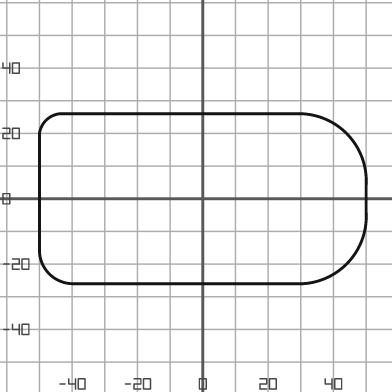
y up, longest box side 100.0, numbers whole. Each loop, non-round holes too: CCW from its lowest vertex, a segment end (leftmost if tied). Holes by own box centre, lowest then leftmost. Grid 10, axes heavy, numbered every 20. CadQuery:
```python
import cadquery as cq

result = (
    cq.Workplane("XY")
    .moveTo(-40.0, -26.0)
    .lineTo(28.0, -26.0)
    .threePointArc((44.0, -20.0), (50.0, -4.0))
    .lineTo(50.0, 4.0)
    .threePointArc((44.0, 20.0), (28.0, 26.0))
    .lineTo(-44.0, 26.0)
    .threePointArc((-48.0, 24.0), (-50.0, 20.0))
    .lineTo(-50.0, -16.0)
    .threePointArc((-47.0, -23.0), (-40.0, -26.0))
    .close()
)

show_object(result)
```